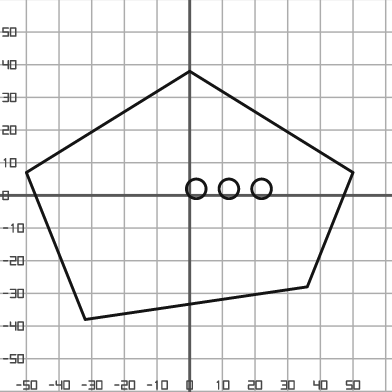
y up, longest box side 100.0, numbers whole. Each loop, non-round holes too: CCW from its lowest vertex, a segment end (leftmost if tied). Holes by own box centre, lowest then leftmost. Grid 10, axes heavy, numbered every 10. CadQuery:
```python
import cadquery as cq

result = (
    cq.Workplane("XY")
    .moveTo(-32.0, -38.0)
    .lineTo(36.0, -28.0)
    .lineTo(50.0, 7.0)
    .lineTo(0.0, 38.0)
    .lineTo(-50.0, 7.0)
    .close()
    .moveTo(2.0, 2.0)
    .circle(3.0)
    .moveTo(12.0, 2.0)
    .circle(3.0)
    .moveTo(22.0, 2.0)
    .circle(3.0)
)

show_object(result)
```